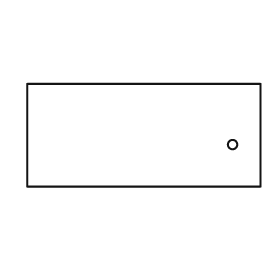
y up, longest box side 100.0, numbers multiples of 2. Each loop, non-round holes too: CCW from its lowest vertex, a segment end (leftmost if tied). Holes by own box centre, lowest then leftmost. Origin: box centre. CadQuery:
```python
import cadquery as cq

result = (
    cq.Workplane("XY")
    .moveTo(-50.0, -22.0)
    .lineTo(50.0, -22.0)
    .lineTo(50.0, 22.0)
    .lineTo(-50.0, 22.0)
    .close()
    .moveTo(38.0, -4.0)
    .circle(2.0)
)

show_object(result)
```